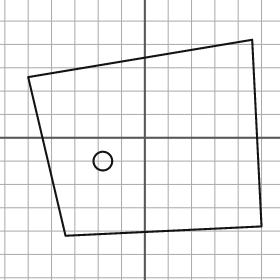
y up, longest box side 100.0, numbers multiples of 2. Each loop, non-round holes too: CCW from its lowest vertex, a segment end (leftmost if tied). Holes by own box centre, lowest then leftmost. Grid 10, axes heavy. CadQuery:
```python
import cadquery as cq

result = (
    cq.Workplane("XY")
    .moveTo(-34.0, -42.0)
    .lineTo(50.0, -38.0)
    .lineTo(46.0, 42.0)
    .lineTo(-50.0, 26.0)
    .close()
    .moveTo(-18.0, -10.0)
    .circle(4.0)
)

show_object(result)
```